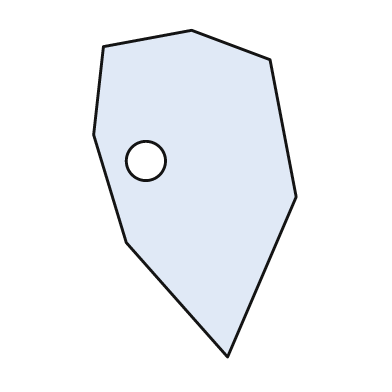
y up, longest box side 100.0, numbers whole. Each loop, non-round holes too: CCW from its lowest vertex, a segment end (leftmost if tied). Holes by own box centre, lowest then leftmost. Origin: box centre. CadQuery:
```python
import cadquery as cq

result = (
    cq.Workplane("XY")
    .moveTo(10.0, -50.0)
    .lineTo(31.0, -1.0)
    .lineTo(23.0, 41.0)
    .lineTo(-1.0, 50.0)
    .lineTo(-28.0, 45.0)
    .lineTo(-31.0, 18.0)
    .lineTo(-21.0, -15.0)
    .close()
    .moveTo(-15.0, 10.0)
    .circle(6.0)
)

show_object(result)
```